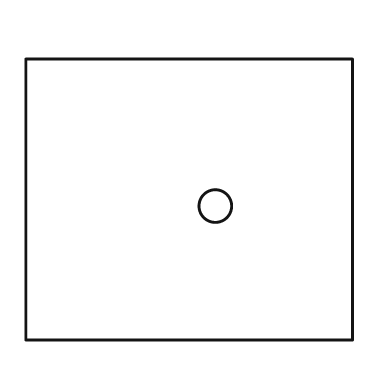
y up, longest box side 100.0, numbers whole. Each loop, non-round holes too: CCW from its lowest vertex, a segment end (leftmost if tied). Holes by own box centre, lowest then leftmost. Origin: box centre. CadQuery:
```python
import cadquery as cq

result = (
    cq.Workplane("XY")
    .moveTo(-50.0, -43.0)
    .lineTo(50.0, -43.0)
    .lineTo(50.0, 43.0)
    .lineTo(-50.0, 43.0)
    .close()
    .moveTo(8.0, -2.0)
    .circle(5.0)
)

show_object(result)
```